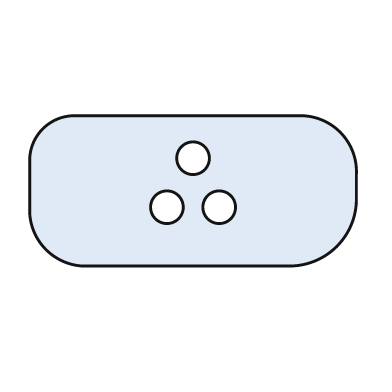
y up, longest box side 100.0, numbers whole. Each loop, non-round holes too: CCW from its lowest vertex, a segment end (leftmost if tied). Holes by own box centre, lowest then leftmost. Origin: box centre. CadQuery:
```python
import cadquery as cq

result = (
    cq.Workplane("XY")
    .moveTo(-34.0, -23.0)
    .lineTo(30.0, -23.0)
    .threePointArc((44.0, -17.0), (50.0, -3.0))
    .lineTo(50.0, 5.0)
    .threePointArc((45.0, 18.0), (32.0, 23.0))
    .lineTo(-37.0, 23.0)
    .threePointArc((-46.0, 19.0), (-50.0, 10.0))
    .lineTo(-50.0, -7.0)
    .threePointArc((-45.0, -18.0), (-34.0, -23.0))
    .close()
    .moveTo(-8.0, -5.0)
    .circle(5.0)
    .moveTo(8.0, -5.0)
    .circle(5.0)
    .moveTo(0.0, 10.0)
    .circle(5.0)
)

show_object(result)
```